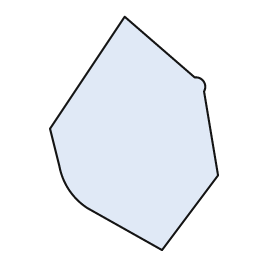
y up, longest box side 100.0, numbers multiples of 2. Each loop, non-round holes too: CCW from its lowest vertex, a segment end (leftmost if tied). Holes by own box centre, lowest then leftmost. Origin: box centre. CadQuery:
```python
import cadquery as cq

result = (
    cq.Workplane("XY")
    .moveTo(12.0, -50.0)
    .lineTo(36.0, -18.0)
    .lineTo(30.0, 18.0)
    .threePointArc((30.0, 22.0), (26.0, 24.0))
    .lineTo(-4.0, 50.0)
    .lineTo(-36.0, 2.0)
    .lineTo(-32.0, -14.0)
    .threePointArc((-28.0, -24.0), (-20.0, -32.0))
    .close()
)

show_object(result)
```